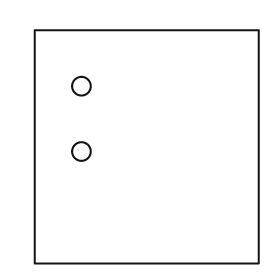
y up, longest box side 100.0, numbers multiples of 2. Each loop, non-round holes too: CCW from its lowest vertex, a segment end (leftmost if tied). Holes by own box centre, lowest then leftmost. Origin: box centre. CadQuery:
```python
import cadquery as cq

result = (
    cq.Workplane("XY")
    .moveTo(-48.0, -50.0)
    .lineTo(48.0, -50.0)
    .lineTo(48.0, 50.0)
    .lineTo(-48.0, 50.0)
    .close()
    .moveTo(-28.0, -2.0)
    .circle(4.0)
    .moveTo(-28.0, 26.0)
    .circle(4.0)
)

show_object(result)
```